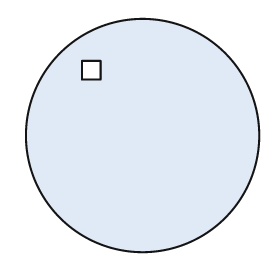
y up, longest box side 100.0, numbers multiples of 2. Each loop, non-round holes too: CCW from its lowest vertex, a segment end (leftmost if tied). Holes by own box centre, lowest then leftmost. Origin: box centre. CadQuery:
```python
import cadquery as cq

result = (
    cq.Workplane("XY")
    .moveTo(0.0, 0.0)
    .circle(50.0)
    .moveTo(-26.0, 24.0)
    .lineTo(-18.0, 24.0)
    .lineTo(-18.0, 32.0)
    .lineTo(-26.0, 32.0)
    .close()
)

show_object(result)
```